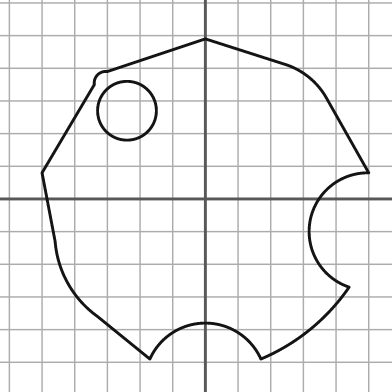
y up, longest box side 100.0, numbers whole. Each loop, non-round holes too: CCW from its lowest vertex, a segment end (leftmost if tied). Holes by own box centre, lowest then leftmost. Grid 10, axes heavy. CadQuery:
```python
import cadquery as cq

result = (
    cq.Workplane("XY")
    .moveTo(-17.0, -49.0)
    .threePointArc((0.0, -38.0), (17.0, -49.0))
    .threePointArc((32.0, -40.0), (44.0, -27.0))
    .threePointArc((32.0, -7.0), (50.0, 8.0))
    .lineTo(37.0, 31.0)
    .threePointArc((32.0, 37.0), (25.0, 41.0))
    .lineTo(0.0, 49.0)
    .lineTo(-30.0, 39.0)
    .threePointArc((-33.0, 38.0), (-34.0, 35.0))
    .lineTo(-50.0, 8.0)
    .lineTo(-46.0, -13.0)
    .threePointArc((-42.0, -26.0), (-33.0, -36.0))
    .close()
    .moveTo(-24.0, 27.0)
    .circle(9.0)
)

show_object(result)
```